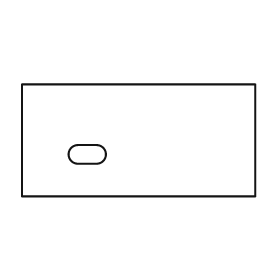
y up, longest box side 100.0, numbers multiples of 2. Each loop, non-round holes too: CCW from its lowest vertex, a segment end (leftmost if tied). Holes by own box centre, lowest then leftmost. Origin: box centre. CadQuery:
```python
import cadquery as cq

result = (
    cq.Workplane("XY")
    .moveTo(-50.0, -24.0)
    .lineTo(50.0, -24.0)
    .lineTo(50.0, 24.0)
    .lineTo(-50.0, 24.0)
    .close()
    .moveTo(-26.0, -10.0)
    .lineTo(-18.0, -10.0)
    .threePointArc((-14.0, -6.0), (-18.0, -2.0))
    .lineTo(-26.0, -2.0)
    .threePointArc((-30.0, -6.0), (-26.0, -10.0))
    .close()
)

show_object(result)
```